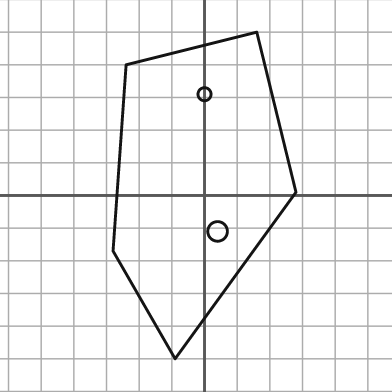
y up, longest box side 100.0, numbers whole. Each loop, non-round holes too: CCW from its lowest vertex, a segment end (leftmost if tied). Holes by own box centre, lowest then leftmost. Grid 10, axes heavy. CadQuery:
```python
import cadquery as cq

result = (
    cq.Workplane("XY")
    .moveTo(-9.0, -50.0)
    .lineTo(28.0, 1.0)
    .lineTo(16.0, 50.0)
    .lineTo(-24.0, 40.0)
    .lineTo(-28.0, -17.0)
    .close()
    .moveTo(4.0, -11.0)
    .circle(3.0)
    .moveTo(0.0, 31.0)
    .circle(2.0)
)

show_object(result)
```